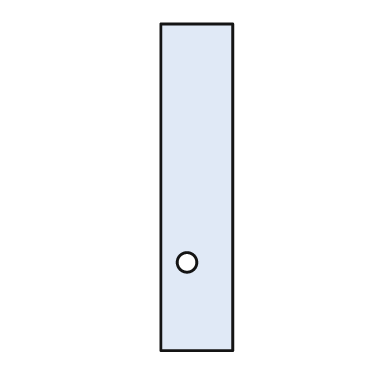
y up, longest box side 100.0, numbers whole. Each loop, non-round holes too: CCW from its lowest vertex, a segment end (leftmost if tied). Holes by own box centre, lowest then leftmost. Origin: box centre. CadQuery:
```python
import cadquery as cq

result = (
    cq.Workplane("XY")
    .moveTo(-11.0, -50.0)
    .lineTo(11.0, -50.0)
    .lineTo(11.0, 50.0)
    .lineTo(-11.0, 50.0)
    .close()
    .moveTo(-3.0, -23.0)
    .circle(3.0)
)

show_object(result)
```